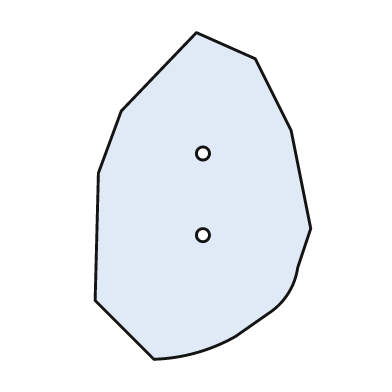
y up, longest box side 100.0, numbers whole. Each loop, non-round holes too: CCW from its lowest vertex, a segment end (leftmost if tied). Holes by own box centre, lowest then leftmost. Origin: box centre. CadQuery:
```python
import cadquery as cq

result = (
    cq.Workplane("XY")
    .moveTo(-15.0, -50.0)
    .threePointArc((-2.0, -48.0), (10.0, -43.0))
    .lineTo(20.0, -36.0)
    .threePointArc((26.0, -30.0), (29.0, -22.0))
    .lineTo(33.0, -10.0)
    .lineTo(27.0, 20.0)
    .lineTo(16.0, 42.0)
    .lineTo(-2.0, 50.0)
    .lineTo(-25.0, 26.0)
    .lineTo(-32.0, 7.0)
    .lineTo(-33.0, -32.0)
    .close()
    .moveTo(0.0, -12.0)
    .circle(2.0)
    .moveTo(0.0, 13.0)
    .circle(2.0)
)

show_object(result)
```